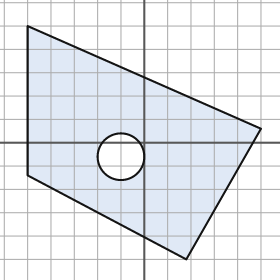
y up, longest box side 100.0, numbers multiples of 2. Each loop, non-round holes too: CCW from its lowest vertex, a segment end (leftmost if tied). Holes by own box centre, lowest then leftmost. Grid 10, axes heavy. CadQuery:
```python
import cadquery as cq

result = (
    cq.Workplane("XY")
    .moveTo(18.0, -50.0)
    .lineTo(50.0, 6.0)
    .lineTo(-50.0, 50.0)
    .lineTo(-50.0, -14.0)
    .close()
    .moveTo(-10.0, -6.0)
    .circle(10.0)
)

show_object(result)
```